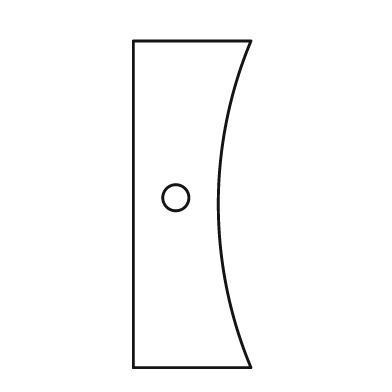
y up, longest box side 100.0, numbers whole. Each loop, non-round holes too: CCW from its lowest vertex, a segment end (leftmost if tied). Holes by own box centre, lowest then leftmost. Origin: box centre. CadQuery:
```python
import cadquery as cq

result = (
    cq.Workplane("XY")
    .moveTo(-18.0, -50.0)
    .lineTo(18.0, -50.0)
    .threePointArc((8.0, 0.0), (18.0, 50.0))
    .lineTo(-18.0, 50.0)
    .close()
    .moveTo(-5.0, 2.0)
    .circle(4.0)
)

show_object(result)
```